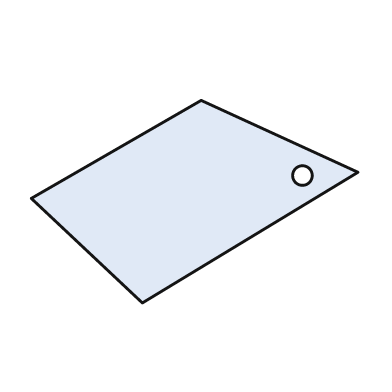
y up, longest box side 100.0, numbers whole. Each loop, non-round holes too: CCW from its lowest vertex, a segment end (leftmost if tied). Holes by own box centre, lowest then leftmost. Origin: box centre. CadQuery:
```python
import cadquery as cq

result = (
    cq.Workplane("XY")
    .moveTo(-16.0, -31.0)
    .lineTo(50.0, 9.0)
    .lineTo(2.0, 31.0)
    .lineTo(-50.0, 1.0)
    .close()
    .moveTo(33.0, 8.0)
    .circle(3.0)
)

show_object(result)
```